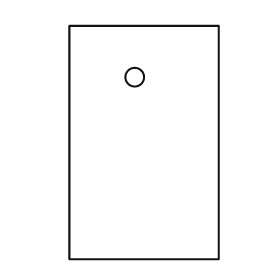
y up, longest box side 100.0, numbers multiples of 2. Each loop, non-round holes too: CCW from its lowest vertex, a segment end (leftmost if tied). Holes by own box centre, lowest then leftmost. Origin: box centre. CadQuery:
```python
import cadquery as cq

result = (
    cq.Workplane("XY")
    .moveTo(-32.0, -50.0)
    .lineTo(32.0, -50.0)
    .lineTo(32.0, 50.0)
    .lineTo(-32.0, 50.0)
    .close()
    .moveTo(-4.0, 28.0)
    .circle(4.0)
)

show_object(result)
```